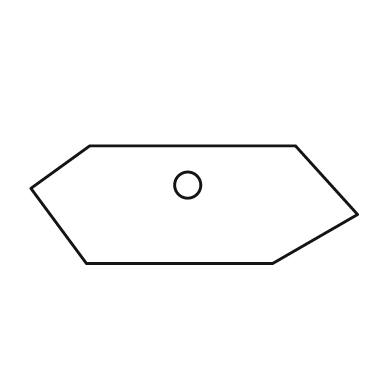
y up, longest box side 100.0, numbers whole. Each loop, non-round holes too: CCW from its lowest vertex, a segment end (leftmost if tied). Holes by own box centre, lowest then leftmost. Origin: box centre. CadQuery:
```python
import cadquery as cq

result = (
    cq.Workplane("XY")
    .moveTo(-33.0, -18.0)
    .lineTo(24.0, -18.0)
    .lineTo(50.0, -3.0)
    .lineTo(31.0, 18.0)
    .lineTo(-32.0, 18.0)
    .lineTo(-50.0, 5.0)
    .close()
    .moveTo(-2.0, 6.0)
    .circle(4.0)
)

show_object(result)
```